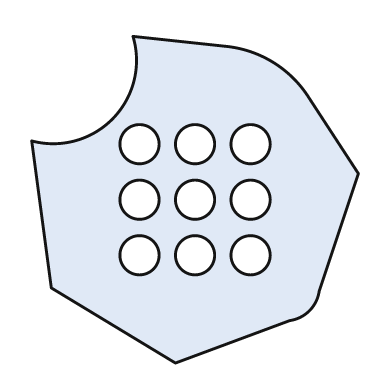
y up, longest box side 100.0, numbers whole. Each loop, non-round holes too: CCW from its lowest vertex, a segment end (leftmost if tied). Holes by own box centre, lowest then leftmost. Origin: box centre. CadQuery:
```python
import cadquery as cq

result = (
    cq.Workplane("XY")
    .moveTo(-6.0, -50.0)
    .lineTo(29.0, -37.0)
    .threePointArc((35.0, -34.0), (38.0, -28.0))
    .lineTo(50.0, 8.0)
    .lineTo(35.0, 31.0)
    .threePointArc((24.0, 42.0), (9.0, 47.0))
    .lineTo(-19.0, 50.0)
    .threePointArc((-25.0, 25.0), (-50.0, 18.0))
    .lineTo(-44.0, -27.0)
    .close()
    .moveTo(-17.0, -17.0)
    .circle(6.0)
    .moveTo(0.0, -17.0)
    .circle(6.0)
    .moveTo(17.0, -17.0)
    .circle(6.0)
    .moveTo(-17.0, 0.0)
    .circle(6.0)
    .moveTo(0.0, 0.0)
    .circle(6.0)
    .moveTo(17.0, 0.0)
    .circle(6.0)
    .moveTo(-17.0, 17.0)
    .circle(6.0)
    .moveTo(0.0, 17.0)
    .circle(6.0)
    .moveTo(17.0, 17.0)
    .circle(6.0)
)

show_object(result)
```